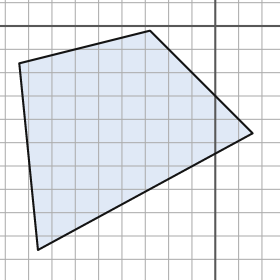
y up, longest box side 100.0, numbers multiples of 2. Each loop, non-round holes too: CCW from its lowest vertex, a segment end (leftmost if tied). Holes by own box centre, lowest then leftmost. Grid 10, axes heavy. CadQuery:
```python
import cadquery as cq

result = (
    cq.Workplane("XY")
    .moveTo(-76.0, -96.0)
    .lineTo(16.0, -46.0)
    .lineTo(-28.0, -2.0)
    .lineTo(-84.0, -16.0)
    .close()
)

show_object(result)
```